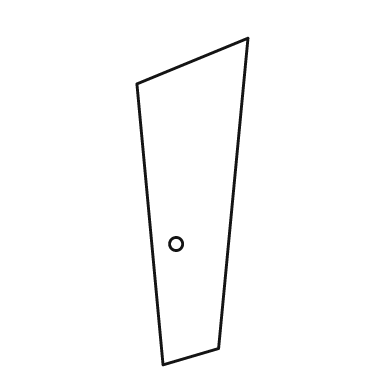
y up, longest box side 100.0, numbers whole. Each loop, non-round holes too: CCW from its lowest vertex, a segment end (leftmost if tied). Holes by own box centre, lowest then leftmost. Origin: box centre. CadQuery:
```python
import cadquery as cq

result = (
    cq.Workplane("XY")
    .moveTo(-9.0, -50.0)
    .lineTo(8.0, -45.0)
    .lineTo(17.0, 50.0)
    .lineTo(-17.0, 36.0)
    .close()
    .moveTo(-5.0, -13.0)
    .circle(2.0)
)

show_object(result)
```